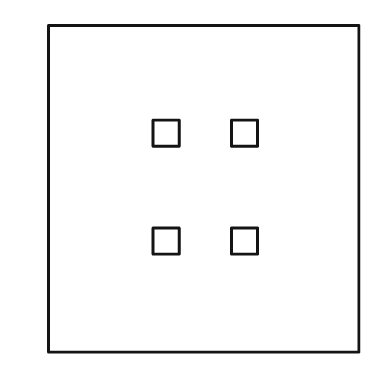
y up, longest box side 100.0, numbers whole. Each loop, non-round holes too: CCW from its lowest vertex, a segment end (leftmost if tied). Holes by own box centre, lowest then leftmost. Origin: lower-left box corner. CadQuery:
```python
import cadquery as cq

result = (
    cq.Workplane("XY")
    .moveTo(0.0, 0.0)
    .lineTo(95.0, 0.0)
    .lineTo(95.0, 100.0)
    .lineTo(0.0, 100.0)
    .close()
    .moveTo(32.0, 30.0)
    .lineTo(40.0, 30.0)
    .lineTo(40.0, 38.0)
    .lineTo(32.0, 38.0)
    .close()
    .moveTo(56.0, 30.0)
    .lineTo(64.0, 30.0)
    .lineTo(64.0, 38.0)
    .lineTo(56.0, 38.0)
    .close()
    .moveTo(32.0, 63.0)
    .lineTo(40.0, 63.0)
    .lineTo(40.0, 71.0)
    .lineTo(32.0, 71.0)
    .close()
    .moveTo(56.0, 63.0)
    .lineTo(64.0, 63.0)
    .lineTo(64.0, 71.0)
    .lineTo(56.0, 71.0)
    .close()
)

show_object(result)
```